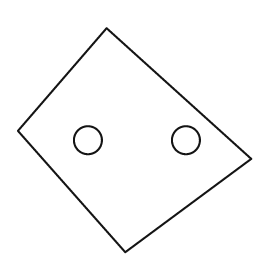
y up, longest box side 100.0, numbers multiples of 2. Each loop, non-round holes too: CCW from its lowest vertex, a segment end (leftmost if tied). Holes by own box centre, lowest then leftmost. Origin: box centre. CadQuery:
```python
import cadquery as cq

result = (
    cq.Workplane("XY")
    .moveTo(-4.0, -48.0)
    .lineTo(50.0, -8.0)
    .lineTo(-12.0, 48.0)
    .lineTo(-50.0, 4.0)
    .close()
    .moveTo(-20.0, 0.0)
    .circle(6.0)
    .moveTo(22.0, 0.0)
    .circle(6.0)
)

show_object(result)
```